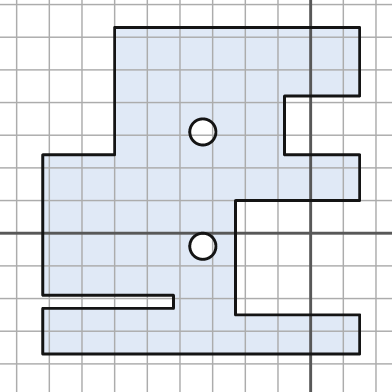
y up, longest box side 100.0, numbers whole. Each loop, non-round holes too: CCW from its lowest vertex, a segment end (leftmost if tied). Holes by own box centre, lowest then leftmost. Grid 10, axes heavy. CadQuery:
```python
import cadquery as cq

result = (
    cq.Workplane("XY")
    .moveTo(-82.0, -37.0)
    .lineTo(15.0, -37.0)
    .lineTo(15.0, -25.0)
    .lineTo(-23.0, -25.0)
    .lineTo(-23.0, 10.0)
    .lineTo(15.0, 10.0)
    .lineTo(15.0, 24.0)
    .lineTo(-8.0, 24.0)
    .lineTo(-8.0, 42.0)
    .lineTo(15.0, 42.0)
    .lineTo(15.0, 63.0)
    .lineTo(-60.0, 63.0)
    .lineTo(-60.0, 24.0)
    .lineTo(-82.0, 24.0)
    .lineTo(-82.0, -19.0)
    .lineTo(-42.0, -19.0)
    .lineTo(-42.0, -23.0)
    .lineTo(-82.0, -23.0)
    .close()
    .moveTo(-33.0, -4.0)
    .circle(4.0)
    .moveTo(-33.0, 31.0)
    .circle(4.0)
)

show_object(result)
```